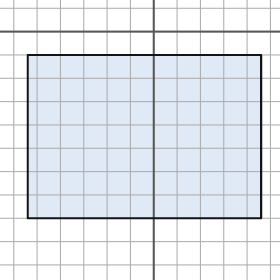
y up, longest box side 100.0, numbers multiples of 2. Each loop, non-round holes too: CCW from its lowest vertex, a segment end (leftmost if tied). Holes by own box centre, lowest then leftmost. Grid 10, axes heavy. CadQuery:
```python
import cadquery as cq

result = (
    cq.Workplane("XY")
    .moveTo(-54.0, -80.0)
    .lineTo(46.0, -80.0)
    .lineTo(46.0, -10.0)
    .lineTo(-54.0, -10.0)
    .close()
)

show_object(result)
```